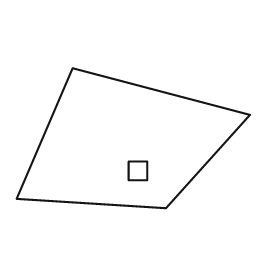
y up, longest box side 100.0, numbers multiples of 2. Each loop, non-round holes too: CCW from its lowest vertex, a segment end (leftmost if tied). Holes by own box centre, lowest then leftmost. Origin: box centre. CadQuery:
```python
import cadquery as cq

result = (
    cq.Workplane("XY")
    .moveTo(14.0, -30.0)
    .lineTo(50.0, 10.0)
    .lineTo(-26.0, 30.0)
    .lineTo(-50.0, -26.0)
    .close()
    .moveTo(-2.0, -18.0)
    .lineTo(6.0, -18.0)
    .lineTo(6.0, -10.0)
    .lineTo(-2.0, -10.0)
    .close()
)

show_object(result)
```